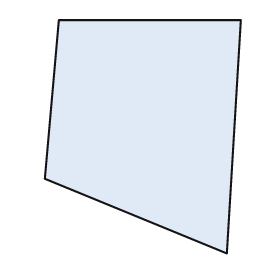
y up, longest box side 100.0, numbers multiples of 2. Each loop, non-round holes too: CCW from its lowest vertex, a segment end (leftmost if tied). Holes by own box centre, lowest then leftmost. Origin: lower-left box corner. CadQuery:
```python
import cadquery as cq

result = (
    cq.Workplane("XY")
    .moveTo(78.0, 0.0)
    .lineTo(84.0, 100.0)
    .lineTo(6.0, 100.0)
    .lineTo(0.0, 32.0)
    .close()
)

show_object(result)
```